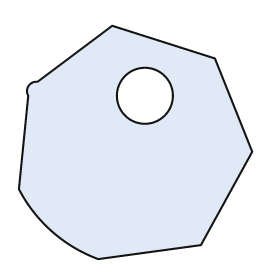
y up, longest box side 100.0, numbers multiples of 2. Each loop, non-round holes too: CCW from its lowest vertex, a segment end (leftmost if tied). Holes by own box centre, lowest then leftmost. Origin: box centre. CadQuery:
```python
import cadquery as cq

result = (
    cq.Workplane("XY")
    .moveTo(-16.0, -50.0)
    .lineTo(28.0, -44.0)
    .lineTo(50.0, -4.0)
    .lineTo(34.0, 36.0)
    .lineTo(-10.0, 50.0)
    .lineTo(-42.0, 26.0)
    .threePointArc((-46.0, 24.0), (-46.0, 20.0))
    .lineTo(-50.0, -20.0)
    .threePointArc((-36.0, -38.0), (-16.0, -50.0))
    .close()
    .moveTo(4.0, 20.0)
    .circle(12.0)
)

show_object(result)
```